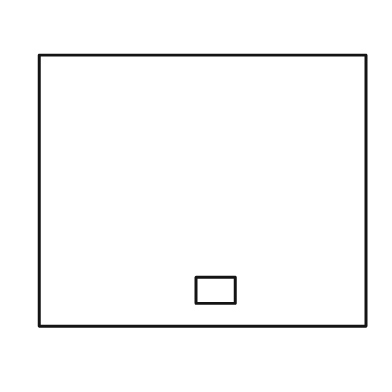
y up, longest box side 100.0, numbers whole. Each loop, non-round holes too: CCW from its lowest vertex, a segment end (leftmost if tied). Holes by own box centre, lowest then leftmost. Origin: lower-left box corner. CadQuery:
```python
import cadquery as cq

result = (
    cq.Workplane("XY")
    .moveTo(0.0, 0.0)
    .lineTo(100.0, 0.0)
    .lineTo(100.0, 83.0)
    .lineTo(0.0, 83.0)
    .close()
    .moveTo(48.0, 7.0)
    .lineTo(60.0, 7.0)
    .lineTo(60.0, 15.0)
    .lineTo(48.0, 15.0)
    .close()
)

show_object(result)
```